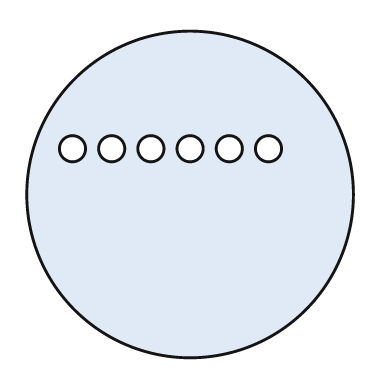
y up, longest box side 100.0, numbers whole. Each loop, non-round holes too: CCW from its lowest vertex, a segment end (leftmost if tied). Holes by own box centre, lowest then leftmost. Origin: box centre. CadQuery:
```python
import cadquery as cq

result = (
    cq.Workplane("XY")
    .moveTo(0.0, 0.0)
    .circle(50.0)
    .moveTo(-36.0, 14.0)
    .circle(4.0)
    .moveTo(-24.0, 14.0)
    .circle(4.0)
    .moveTo(-12.0, 14.0)
    .circle(4.0)
    .moveTo(0.0, 14.0)
    .circle(4.0)
    .moveTo(12.0, 14.0)
    .circle(4.0)
    .moveTo(24.0, 14.0)
    .circle(4.0)
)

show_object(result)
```